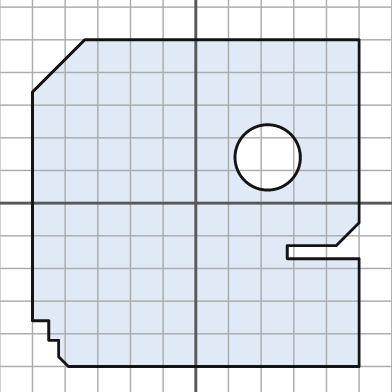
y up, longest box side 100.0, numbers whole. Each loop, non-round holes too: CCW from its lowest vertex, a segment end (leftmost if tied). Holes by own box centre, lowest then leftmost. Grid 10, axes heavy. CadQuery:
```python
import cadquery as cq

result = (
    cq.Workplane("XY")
    .moveTo(-39.0, -50.0)
    .lineTo(50.0, -50.0)
    .lineTo(50.0, -17.0)
    .lineTo(28.0, -17.0)
    .lineTo(28.0, -13.0)
    .lineTo(43.0, -13.0)
    .lineTo(50.0, -6.0)
    .lineTo(50.0, 50.0)
    .lineTo(-34.0, 50.0)
    .lineTo(-50.0, 34.0)
    .lineTo(-50.0, -36.0)
    .lineTo(-45.0, -36.0)
    .lineTo(-45.0, -42.0)
    .lineTo(-42.0, -42.0)
    .lineTo(-42.0, -47.0)
    .close()
    .moveTo(22.0, 14.0)
    .circle(10.0)
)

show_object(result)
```